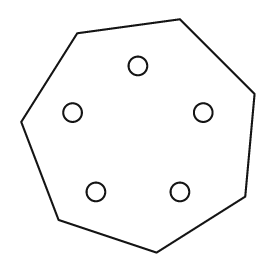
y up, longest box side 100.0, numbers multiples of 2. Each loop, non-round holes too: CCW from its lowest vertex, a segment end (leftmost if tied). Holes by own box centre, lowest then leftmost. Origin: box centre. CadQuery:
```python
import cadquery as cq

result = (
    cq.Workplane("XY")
    .moveTo(8.0, -50.0)
    .lineTo(46.0, -26.0)
    .lineTo(50.0, 18.0)
    .lineTo(18.0, 50.0)
    .lineTo(-26.0, 44.0)
    .lineTo(-50.0, 6.0)
    .lineTo(-34.0, -36.0)
    .close()
    .moveTo(-18.0, -24.0)
    .circle(4.0)
    .moveTo(18.0, -24.0)
    .circle(4.0)
    .moveTo(-28.0, 10.0)
    .circle(4.0)
    .moveTo(28.0, 10.0)
    .circle(4.0)
    .moveTo(0.0, 30.0)
    .circle(4.0)
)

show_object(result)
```